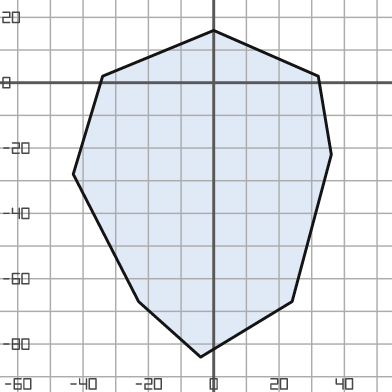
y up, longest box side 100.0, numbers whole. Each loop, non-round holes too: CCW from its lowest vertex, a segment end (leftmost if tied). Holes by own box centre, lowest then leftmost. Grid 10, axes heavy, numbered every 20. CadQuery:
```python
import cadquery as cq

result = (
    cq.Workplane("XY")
    .moveTo(-4.0, -84.0)
    .lineTo(24.0, -67.0)
    .lineTo(36.0, -22.0)
    .lineTo(32.0, 2.0)
    .lineTo(0.0, 16.0)
    .lineTo(-34.0, 2.0)
    .lineTo(-43.0, -28.0)
    .lineTo(-23.0, -67.0)
    .close()
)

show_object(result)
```